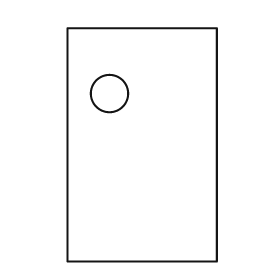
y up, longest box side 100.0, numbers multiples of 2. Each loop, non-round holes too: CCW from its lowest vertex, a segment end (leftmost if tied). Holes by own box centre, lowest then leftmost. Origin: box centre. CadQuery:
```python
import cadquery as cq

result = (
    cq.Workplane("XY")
    .moveTo(-32.0, -50.0)
    .lineTo(32.0, -50.0)
    .lineTo(32.0, 50.0)
    .lineTo(-32.0, 50.0)
    .close()
    .moveTo(-14.0, 22.0)
    .circle(8.0)
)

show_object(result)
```